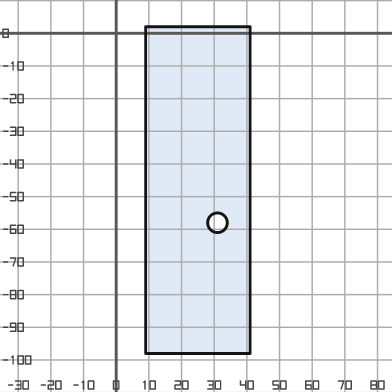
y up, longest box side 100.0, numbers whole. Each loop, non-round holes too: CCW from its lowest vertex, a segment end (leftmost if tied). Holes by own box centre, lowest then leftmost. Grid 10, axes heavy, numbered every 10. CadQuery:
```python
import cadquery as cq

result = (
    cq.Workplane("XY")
    .moveTo(9.0, -98.0)
    .lineTo(41.0, -98.0)
    .lineTo(41.0, 2.0)
    .lineTo(9.0, 2.0)
    .close()
    .moveTo(31.0, -58.0)
    .circle(3.0)
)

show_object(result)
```